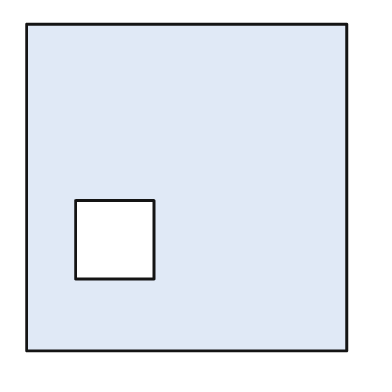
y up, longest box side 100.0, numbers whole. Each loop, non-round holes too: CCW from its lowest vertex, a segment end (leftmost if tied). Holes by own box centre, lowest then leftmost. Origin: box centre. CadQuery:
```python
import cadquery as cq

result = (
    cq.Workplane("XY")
    .moveTo(-49.0, -50.0)
    .lineTo(49.0, -50.0)
    .lineTo(49.0, 50.0)
    .lineTo(-49.0, 50.0)
    .close()
    .moveTo(-34.0, -28.0)
    .lineTo(-10.0, -28.0)
    .lineTo(-10.0, -4.0)
    .lineTo(-34.0, -4.0)
    .close()
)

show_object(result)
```